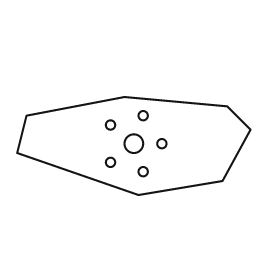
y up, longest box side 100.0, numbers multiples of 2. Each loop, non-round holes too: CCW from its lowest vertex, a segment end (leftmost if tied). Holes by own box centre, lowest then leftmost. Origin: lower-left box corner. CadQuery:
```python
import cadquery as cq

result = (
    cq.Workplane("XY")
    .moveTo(52.0, 0.0)
    .lineTo(88.0, 6.0)
    .lineTo(100.0, 28.0)
    .lineTo(90.0, 38.0)
    .lineTo(46.0, 42.0)
    .lineTo(4.0, 34.0)
    .lineTo(0.0, 18.0)
    .close()
    .moveTo(54.0, 10.0)
    .circle(2.0)
    .moveTo(40.0, 14.0)
    .circle(2.0)
    .moveTo(50.0, 22.0)
    .circle(4.0)
    .moveTo(62.0, 22.0)
    .circle(2.0)
    .moveTo(40.0, 30.0)
    .circle(2.0)
    .moveTo(54.0, 34.0)
    .circle(2.0)
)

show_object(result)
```